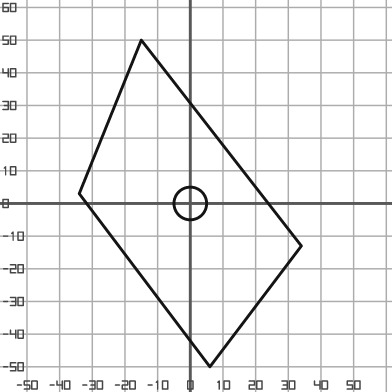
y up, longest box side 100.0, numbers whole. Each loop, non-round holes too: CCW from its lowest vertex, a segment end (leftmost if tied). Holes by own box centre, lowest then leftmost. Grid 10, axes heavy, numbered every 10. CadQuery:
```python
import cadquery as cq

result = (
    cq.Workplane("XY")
    .moveTo(6.0, -50.0)
    .lineTo(34.0, -13.0)
    .lineTo(-15.0, 50.0)
    .lineTo(-34.0, 3.0)
    .close()
    .moveTo(0.0, 0.0)
    .circle(5.0)
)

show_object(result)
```